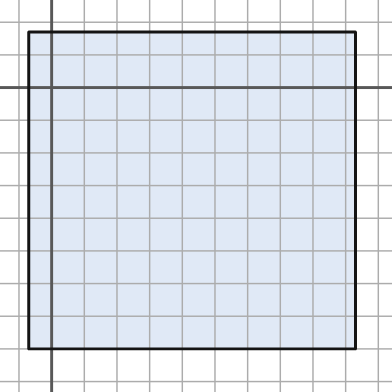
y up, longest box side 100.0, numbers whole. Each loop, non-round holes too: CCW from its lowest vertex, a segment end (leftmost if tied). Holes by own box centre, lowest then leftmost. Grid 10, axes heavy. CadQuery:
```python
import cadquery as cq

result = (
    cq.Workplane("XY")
    .moveTo(-7.0, -80.0)
    .lineTo(93.0, -80.0)
    .lineTo(93.0, 17.0)
    .lineTo(-7.0, 17.0)
    .close()
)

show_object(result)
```